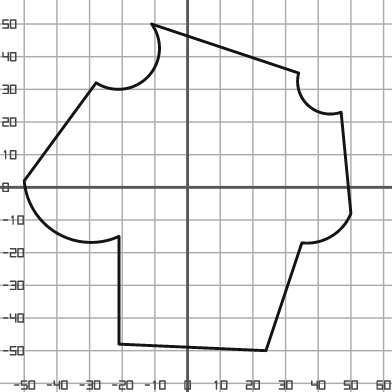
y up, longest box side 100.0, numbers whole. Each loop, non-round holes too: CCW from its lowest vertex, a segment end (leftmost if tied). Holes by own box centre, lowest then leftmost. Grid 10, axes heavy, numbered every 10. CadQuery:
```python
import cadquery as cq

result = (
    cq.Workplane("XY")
    .moveTo(24.0, -50.0)
    .lineTo(35.0, -17.0)
    .threePointArc((44.0, -15.0), (50.0, -8.0))
    .lineTo(47.0, 23.0)
    .threePointArc((37.0, 25.0), (34.0, 35.0))
    .lineTo(-11.0, 50.0)
    .threePointArc((-12.0, 34.0), (-28.0, 32.0))
    .lineTo(-50.0, 2.0)
    .threePointArc((-40.0, -14.0), (-21.0, -15.0))
    .lineTo(-21.0, -48.0)
    .close()
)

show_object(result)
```